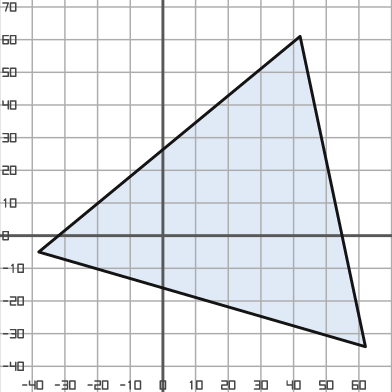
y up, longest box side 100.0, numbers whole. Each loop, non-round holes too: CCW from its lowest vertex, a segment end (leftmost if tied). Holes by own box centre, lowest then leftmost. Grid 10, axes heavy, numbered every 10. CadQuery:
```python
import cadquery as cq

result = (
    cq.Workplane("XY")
    .moveTo(62.0, -34.0)
    .lineTo(42.0, 61.0)
    .lineTo(-38.0, -5.0)
    .close()
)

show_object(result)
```